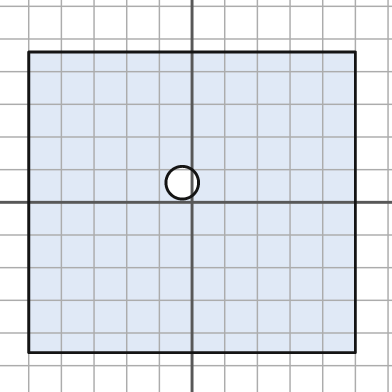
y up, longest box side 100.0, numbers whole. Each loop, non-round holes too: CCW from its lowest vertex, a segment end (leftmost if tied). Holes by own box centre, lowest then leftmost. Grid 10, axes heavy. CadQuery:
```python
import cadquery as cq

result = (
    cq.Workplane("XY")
    .moveTo(-50.0, -46.0)
    .lineTo(50.0, -46.0)
    .lineTo(50.0, 46.0)
    .lineTo(-50.0, 46.0)
    .close()
    .moveTo(-3.0, 6.0)
    .circle(5.0)
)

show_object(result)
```